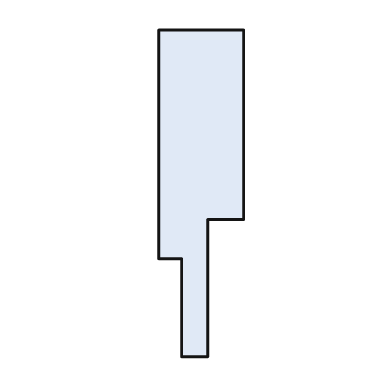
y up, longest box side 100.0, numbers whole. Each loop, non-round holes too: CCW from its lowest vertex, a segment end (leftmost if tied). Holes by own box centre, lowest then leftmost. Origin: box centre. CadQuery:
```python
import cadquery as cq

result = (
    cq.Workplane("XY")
    .moveTo(-6.0, -50.0)
    .lineTo(2.0, -50.0)
    .lineTo(2.0, -8.0)
    .lineTo(13.0, -8.0)
    .lineTo(13.0, 50.0)
    .lineTo(-13.0, 50.0)
    .lineTo(-13.0, -20.0)
    .lineTo(-6.0, -20.0)
    .close()
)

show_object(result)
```